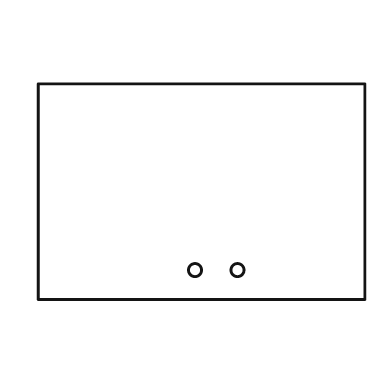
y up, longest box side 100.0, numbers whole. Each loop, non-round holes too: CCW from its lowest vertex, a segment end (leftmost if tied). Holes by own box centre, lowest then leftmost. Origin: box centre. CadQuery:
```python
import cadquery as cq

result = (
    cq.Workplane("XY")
    .moveTo(-50.0, -33.0)
    .lineTo(50.0, -33.0)
    .lineTo(50.0, 33.0)
    .lineTo(-50.0, 33.0)
    .close()
    .moveTo(-2.0, -24.0)
    .circle(2.0)
    .moveTo(11.0, -24.0)
    .circle(2.0)
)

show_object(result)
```